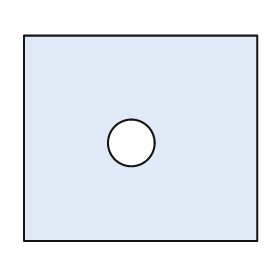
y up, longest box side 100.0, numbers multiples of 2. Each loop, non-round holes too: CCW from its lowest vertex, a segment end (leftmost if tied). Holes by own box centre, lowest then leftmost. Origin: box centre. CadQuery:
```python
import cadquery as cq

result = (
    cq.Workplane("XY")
    .moveTo(-50.0, -44.0)
    .lineTo(50.0, -44.0)
    .lineTo(50.0, 44.0)
    .lineTo(-50.0, 44.0)
    .close()
    .moveTo(-4.0, -2.0)
    .circle(10.0)
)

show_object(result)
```